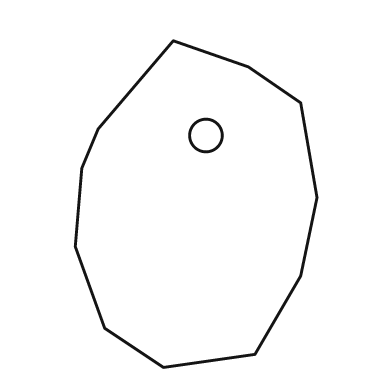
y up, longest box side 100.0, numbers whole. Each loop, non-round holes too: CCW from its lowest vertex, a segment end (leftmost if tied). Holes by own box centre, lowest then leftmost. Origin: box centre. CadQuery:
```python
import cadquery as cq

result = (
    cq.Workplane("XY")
    .moveTo(-10.0, -50.0)
    .lineTo(18.0, -46.0)
    .lineTo(32.0, -22.0)
    .lineTo(37.0, 2.0)
    .lineTo(32.0, 31.0)
    .lineTo(16.0, 42.0)
    .lineTo(-7.0, 50.0)
    .lineTo(-30.0, 23.0)
    .lineTo(-35.0, 11.0)
    .lineTo(-37.0, -13.0)
    .lineTo(-28.0, -38.0)
    .close()
    .moveTo(3.0, 21.0)
    .circle(5.0)
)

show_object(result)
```